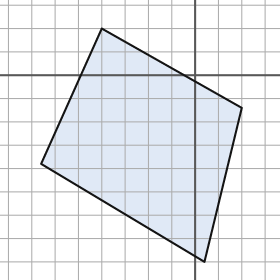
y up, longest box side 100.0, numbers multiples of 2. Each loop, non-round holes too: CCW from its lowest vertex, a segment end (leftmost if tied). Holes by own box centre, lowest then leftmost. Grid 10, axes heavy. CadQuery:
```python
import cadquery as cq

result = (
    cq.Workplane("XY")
    .moveTo(4.0, -80.0)
    .lineTo(20.0, -14.0)
    .lineTo(-40.0, 20.0)
    .lineTo(-66.0, -38.0)
    .close()
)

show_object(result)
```